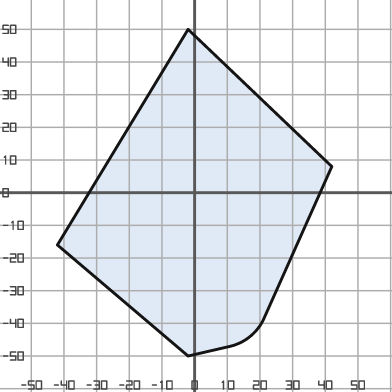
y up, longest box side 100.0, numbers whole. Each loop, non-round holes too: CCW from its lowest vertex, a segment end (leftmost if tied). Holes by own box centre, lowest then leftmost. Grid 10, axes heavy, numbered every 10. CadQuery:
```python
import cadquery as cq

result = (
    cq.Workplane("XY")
    .moveTo(-2.0, -50.0)
    .lineTo(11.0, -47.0)
    .threePointArc((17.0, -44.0), (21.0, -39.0))
    .lineTo(42.0, 8.0)
    .lineTo(-2.0, 50.0)
    .lineTo(-42.0, -16.0)
    .close()
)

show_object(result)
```